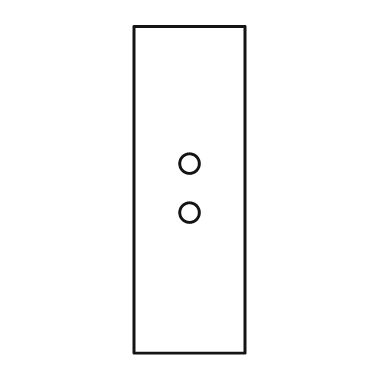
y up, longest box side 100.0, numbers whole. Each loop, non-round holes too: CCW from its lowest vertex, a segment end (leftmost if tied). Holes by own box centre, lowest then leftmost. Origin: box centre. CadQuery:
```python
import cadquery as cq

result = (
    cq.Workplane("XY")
    .moveTo(-17.0, -50.0)
    .lineTo(17.0, -50.0)
    .lineTo(17.0, 50.0)
    .lineTo(-17.0, 50.0)
    .close()
    .moveTo(0.0, -7.0)
    .circle(3.0)
    .moveTo(0.0, 8.0)
    .circle(3.0)
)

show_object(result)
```